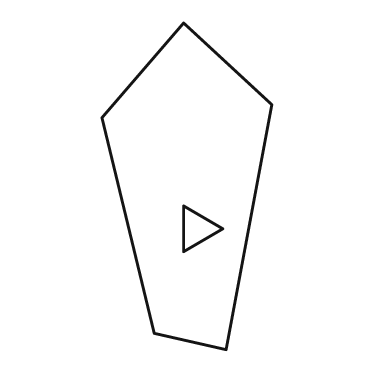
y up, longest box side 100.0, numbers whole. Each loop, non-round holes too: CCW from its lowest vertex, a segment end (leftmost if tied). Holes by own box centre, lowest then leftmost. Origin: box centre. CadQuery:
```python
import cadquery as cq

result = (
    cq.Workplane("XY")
    .moveTo(12.0, -50.0)
    .lineTo(26.0, 25.0)
    .lineTo(-1.0, 50.0)
    .lineTo(-26.0, 21.0)
    .lineTo(-10.0, -45.0)
    .close()
    .moveTo(-1.0, -20.0)
    .lineTo(11.0, -13.0)
    .lineTo(-1.0, -6.0)
    .close()
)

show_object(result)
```